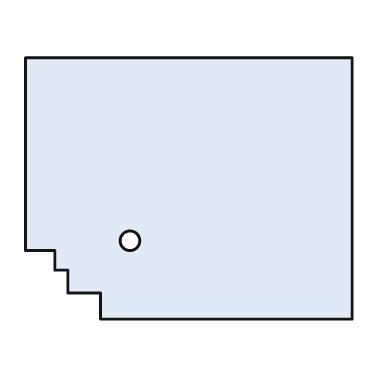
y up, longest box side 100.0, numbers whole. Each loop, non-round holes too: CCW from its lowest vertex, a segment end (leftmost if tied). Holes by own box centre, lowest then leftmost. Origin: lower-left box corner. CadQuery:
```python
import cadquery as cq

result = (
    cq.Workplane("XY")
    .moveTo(23.0, 0.0)
    .lineTo(100.0, 0.0)
    .lineTo(100.0, 80.0)
    .lineTo(0.0, 80.0)
    .lineTo(0.0, 21.0)
    .lineTo(9.0, 21.0)
    .lineTo(9.0, 15.0)
    .lineTo(13.0, 15.0)
    .lineTo(13.0, 8.0)
    .lineTo(23.0, 8.0)
    .close()
    .moveTo(32.0, 24.0)
    .circle(3.0)
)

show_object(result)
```